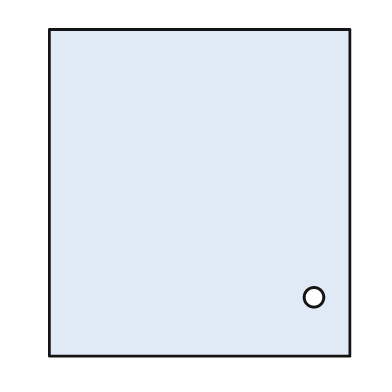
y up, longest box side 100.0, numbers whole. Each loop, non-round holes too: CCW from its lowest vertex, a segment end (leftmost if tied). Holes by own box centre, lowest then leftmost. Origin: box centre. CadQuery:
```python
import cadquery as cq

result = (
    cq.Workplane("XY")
    .moveTo(-46.0, -50.0)
    .lineTo(46.0, -50.0)
    .lineTo(46.0, 50.0)
    .lineTo(-46.0, 50.0)
    .close()
    .moveTo(35.0, -32.0)
    .circle(3.0)
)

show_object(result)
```